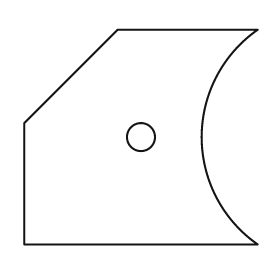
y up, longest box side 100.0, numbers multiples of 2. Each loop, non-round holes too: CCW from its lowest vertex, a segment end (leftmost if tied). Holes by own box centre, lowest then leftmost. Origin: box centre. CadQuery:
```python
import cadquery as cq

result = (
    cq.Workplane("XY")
    .moveTo(-50.0, -46.0)
    .lineTo(50.0, -46.0)
    .threePointArc((26.0, 0.0), (50.0, 46.0))
    .lineTo(-10.0, 46.0)
    .lineTo(-50.0, 6.0)
    .close()
    .moveTo(0.0, 0.0)
    .circle(6.0)
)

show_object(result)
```